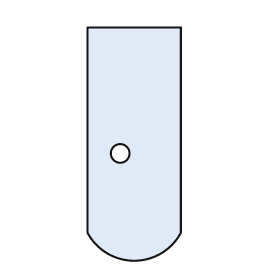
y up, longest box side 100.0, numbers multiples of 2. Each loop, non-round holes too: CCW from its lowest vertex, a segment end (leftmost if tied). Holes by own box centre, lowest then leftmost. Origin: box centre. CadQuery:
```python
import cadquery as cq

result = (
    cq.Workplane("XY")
    .moveTo(-20.0, -38.0)
    .threePointArc((0.0, -50.0), (20.0, -38.0))
    .lineTo(20.0, 50.0)
    .lineTo(-20.0, 50.0)
    .close()
    .moveTo(-6.0, -4.0)
    .circle(4.0)
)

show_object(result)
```